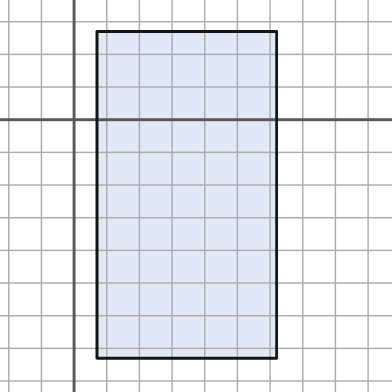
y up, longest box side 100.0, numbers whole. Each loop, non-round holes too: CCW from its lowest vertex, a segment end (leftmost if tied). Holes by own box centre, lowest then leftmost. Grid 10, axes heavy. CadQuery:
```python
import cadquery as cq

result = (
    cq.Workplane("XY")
    .moveTo(7.0, -73.0)
    .lineTo(62.0, -73.0)
    .lineTo(62.0, 27.0)
    .lineTo(7.0, 27.0)
    .close()
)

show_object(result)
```